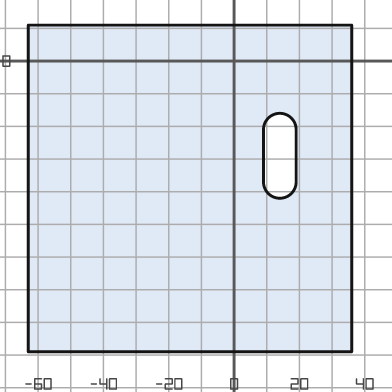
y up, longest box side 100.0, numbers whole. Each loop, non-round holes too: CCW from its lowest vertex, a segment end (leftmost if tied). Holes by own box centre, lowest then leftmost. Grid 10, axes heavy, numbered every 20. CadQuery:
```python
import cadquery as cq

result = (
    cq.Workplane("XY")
    .moveTo(-63.0, -89.0)
    .lineTo(36.0, -89.0)
    .lineTo(36.0, 11.0)
    .lineTo(-63.0, 11.0)
    .close()
    .moveTo(9.0, -37.0)
    .threePointArc((14.0, -42.0), (19.0, -37.0))
    .lineTo(19.0, -21.0)
    .threePointArc((14.0, -16.0), (9.0, -21.0))
    .close()
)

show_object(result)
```